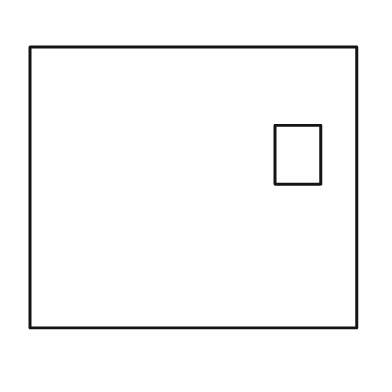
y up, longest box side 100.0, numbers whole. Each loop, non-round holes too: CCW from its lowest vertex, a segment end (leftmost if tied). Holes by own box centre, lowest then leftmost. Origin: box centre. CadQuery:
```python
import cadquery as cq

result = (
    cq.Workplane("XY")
    .moveTo(-50.0, -43.0)
    .lineTo(50.0, -43.0)
    .lineTo(50.0, 43.0)
    .lineTo(-50.0, 43.0)
    .close()
    .moveTo(25.0, 1.0)
    .lineTo(39.0, 1.0)
    .lineTo(39.0, 19.0)
    .lineTo(25.0, 19.0)
    .close()
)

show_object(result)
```